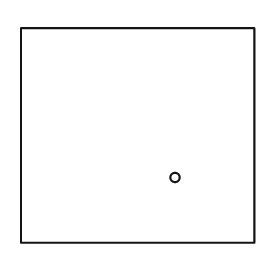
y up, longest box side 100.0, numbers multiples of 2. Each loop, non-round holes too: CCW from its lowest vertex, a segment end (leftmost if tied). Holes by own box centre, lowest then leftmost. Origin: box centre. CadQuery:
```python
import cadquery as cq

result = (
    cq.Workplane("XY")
    .moveTo(-50.0, -46.0)
    .lineTo(50.0, -46.0)
    .lineTo(50.0, 46.0)
    .lineTo(-50.0, 46.0)
    .close()
    .moveTo(16.0, -18.0)
    .circle(2.0)
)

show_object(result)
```